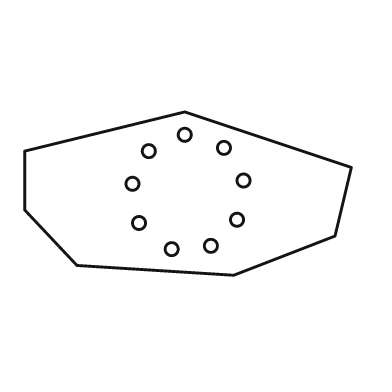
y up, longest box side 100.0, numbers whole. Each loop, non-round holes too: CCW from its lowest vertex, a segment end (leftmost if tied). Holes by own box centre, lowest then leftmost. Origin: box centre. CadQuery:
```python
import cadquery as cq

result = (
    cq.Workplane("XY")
    .moveTo(14.0, -25.0)
    .lineTo(45.0, -13.0)
    .lineTo(50.0, 8.0)
    .lineTo(-1.0, 25.0)
    .lineTo(-50.0, 13.0)
    .lineTo(-50.0, -5.0)
    .lineTo(-34.0, -22.0)
    .close()
    .moveTo(-5.0, -17.0)
    .circle(2.0)
    .moveTo(7.0, -16.0)
    .circle(2.0)
    .moveTo(-15.0, -9.0)
    .circle(2.0)
    .moveTo(15.0, -8.0)
    .circle(2.0)
    .moveTo(-17.0, 3.0)
    .circle(2.0)
    .moveTo(17.0, 4.0)
    .circle(2.0)
    .moveTo(-12.0, 13.0)
    .circle(2.0)
    .moveTo(11.0, 14.0)
    .circle(2.0)
    .moveTo(-1.0, 18.0)
    .circle(2.0)
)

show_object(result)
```